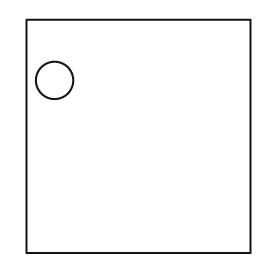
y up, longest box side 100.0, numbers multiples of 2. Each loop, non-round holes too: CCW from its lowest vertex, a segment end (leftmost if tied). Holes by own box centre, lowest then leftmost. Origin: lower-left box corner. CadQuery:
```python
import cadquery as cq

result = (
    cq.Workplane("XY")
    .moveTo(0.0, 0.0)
    .lineTo(96.0, 0.0)
    .lineTo(96.0, 100.0)
    .lineTo(0.0, 100.0)
    .close()
    .moveTo(12.0, 74.0)
    .circle(8.0)
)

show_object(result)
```